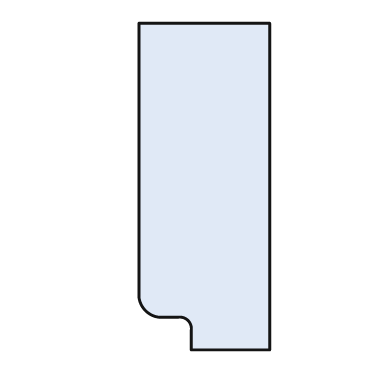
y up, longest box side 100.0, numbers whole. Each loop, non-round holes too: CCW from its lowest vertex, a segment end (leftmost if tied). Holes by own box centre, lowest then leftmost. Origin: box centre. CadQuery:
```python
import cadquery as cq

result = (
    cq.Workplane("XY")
    .moveTo(-4.0, -50.0)
    .lineTo(20.0, -50.0)
    .lineTo(20.0, 50.0)
    .lineTo(-20.0, 50.0)
    .lineTo(-20.0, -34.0)
    .threePointArc((-18.0, -38.0), (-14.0, -40.0))
    .lineTo(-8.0, -40.0)
    .threePointArc((-5.0, -41.0), (-4.0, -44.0))
    .close()
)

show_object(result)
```